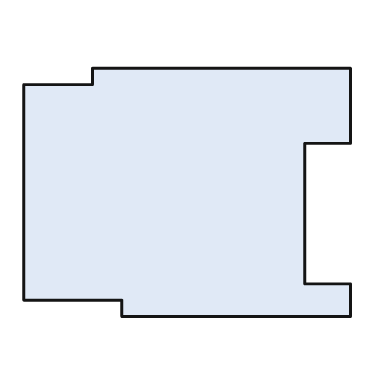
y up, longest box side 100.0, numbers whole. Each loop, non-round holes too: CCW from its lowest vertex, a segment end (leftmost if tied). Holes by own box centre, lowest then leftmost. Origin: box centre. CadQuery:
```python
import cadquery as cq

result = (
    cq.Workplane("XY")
    .moveTo(-20.0, -38.0)
    .lineTo(50.0, -38.0)
    .lineTo(50.0, -28.0)
    .lineTo(36.0, -28.0)
    .lineTo(36.0, 15.0)
    .lineTo(50.0, 15.0)
    .lineTo(50.0, 38.0)
    .lineTo(-29.0, 38.0)
    .lineTo(-29.0, 33.0)
    .lineTo(-50.0, 33.0)
    .lineTo(-50.0, -33.0)
    .lineTo(-20.0, -33.0)
    .close()
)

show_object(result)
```